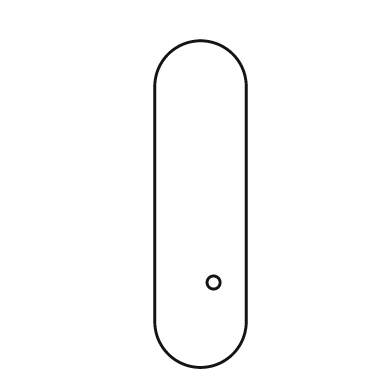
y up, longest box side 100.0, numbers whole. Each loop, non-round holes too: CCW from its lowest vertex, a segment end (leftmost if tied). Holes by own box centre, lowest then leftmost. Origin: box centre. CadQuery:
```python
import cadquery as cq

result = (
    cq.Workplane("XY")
    .moveTo(-14.0, -36.0)
    .threePointArc((0.0, -50.0), (14.0, -36.0))
    .lineTo(14.0, 36.0)
    .threePointArc((0.0, 50.0), (-14.0, 36.0))
    .close()
    .moveTo(4.0, -24.0)
    .circle(2.0)
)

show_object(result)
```